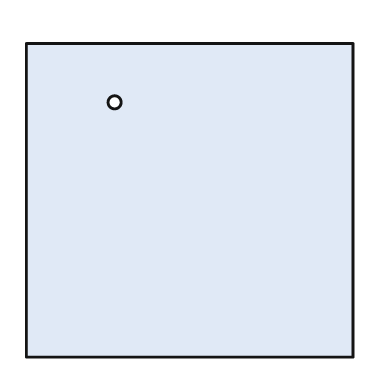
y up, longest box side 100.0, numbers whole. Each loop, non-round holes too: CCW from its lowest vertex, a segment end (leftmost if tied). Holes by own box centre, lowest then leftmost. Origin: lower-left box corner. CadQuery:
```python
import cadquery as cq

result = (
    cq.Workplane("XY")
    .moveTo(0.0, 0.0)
    .lineTo(100.0, 0.0)
    .lineTo(100.0, 96.0)
    .lineTo(0.0, 96.0)
    .close()
    .moveTo(27.0, 78.0)
    .circle(2.0)
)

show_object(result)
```